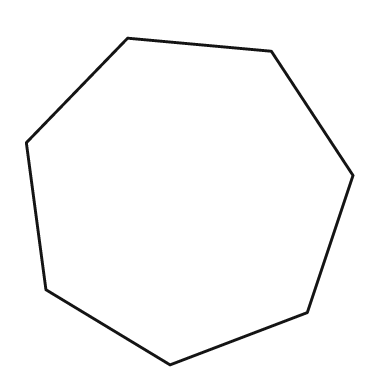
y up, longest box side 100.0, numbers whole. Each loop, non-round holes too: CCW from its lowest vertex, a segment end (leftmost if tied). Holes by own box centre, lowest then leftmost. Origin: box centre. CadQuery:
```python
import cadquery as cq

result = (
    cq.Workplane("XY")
    .moveTo(-6.0, -50.0)
    .lineTo(36.0, -34.0)
    .lineTo(50.0, 8.0)
    .lineTo(25.0, 46.0)
    .lineTo(-19.0, 50.0)
    .lineTo(-50.0, 18.0)
    .lineTo(-44.0, -27.0)
    .close()
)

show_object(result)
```